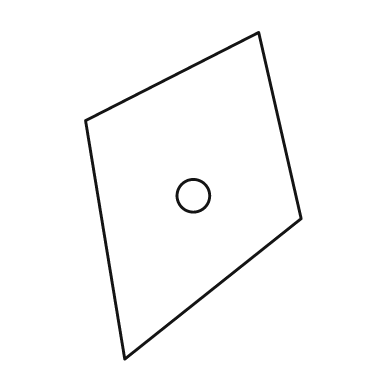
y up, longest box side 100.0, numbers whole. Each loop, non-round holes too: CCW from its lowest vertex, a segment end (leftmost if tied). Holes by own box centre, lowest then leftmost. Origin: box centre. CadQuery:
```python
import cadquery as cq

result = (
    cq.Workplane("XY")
    .moveTo(-21.0, -50.0)
    .lineTo(33.0, -7.0)
    .lineTo(20.0, 50.0)
    .lineTo(-33.0, 23.0)
    .close()
    .moveTo(0.0, 0.0)
    .circle(5.0)
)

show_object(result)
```